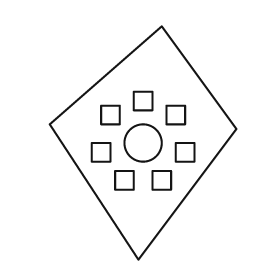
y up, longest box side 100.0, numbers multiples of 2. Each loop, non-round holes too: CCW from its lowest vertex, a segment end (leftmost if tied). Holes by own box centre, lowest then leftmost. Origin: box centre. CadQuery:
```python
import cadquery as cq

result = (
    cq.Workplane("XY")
    .moveTo(-2.0, -50.0)
    .lineTo(40.0, 6.0)
    .lineTo(8.0, 50.0)
    .lineTo(-40.0, 8.0)
    .close()
    .moveTo(-12.0, -20.0)
    .lineTo(-4.0, -20.0)
    .lineTo(-4.0, -12.0)
    .lineTo(-12.0, -12.0)
    .close()
    .moveTo(4.0, -20.0)
    .lineTo(12.0, -20.0)
    .lineTo(12.0, -12.0)
    .lineTo(4.0, -12.0)
    .close()
    .moveTo(-22.0, -8.0)
    .lineTo(-14.0, -8.0)
    .lineTo(-14.0, 0.0)
    .lineTo(-22.0, 0.0)
    .close()
    .moveTo(14.0, -8.0)
    .lineTo(22.0, -8.0)
    .lineTo(22.0, 0.0)
    .lineTo(14.0, 0.0)
    .close()
    .moveTo(0.0, 0.0)
    .circle(8.0)
    .moveTo(-18.0, 8.0)
    .lineTo(-10.0, 8.0)
    .lineTo(-10.0, 16.0)
    .lineTo(-18.0, 16.0)
    .close()
    .moveTo(10.0, 8.0)
    .lineTo(18.0, 8.0)
    .lineTo(18.0, 16.0)
    .lineTo(10.0, 16.0)
    .close()
    .moveTo(-4.0, 14.0)
    .lineTo(4.0, 14.0)
    .lineTo(4.0, 22.0)
    .lineTo(-4.0, 22.0)
    .close()
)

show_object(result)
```